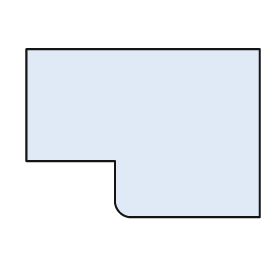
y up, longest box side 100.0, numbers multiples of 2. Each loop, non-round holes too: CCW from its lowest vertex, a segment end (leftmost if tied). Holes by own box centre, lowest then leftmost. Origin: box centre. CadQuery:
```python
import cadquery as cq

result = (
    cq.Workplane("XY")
    .moveTo(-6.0, -36.0)
    .lineTo(50.0, -36.0)
    .lineTo(50.0, 36.0)
    .lineTo(-50.0, 36.0)
    .lineTo(-50.0, -12.0)
    .lineTo(-12.0, -12.0)
    .lineTo(-12.0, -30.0)
    .threePointArc((-10.0, -34.0), (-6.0, -36.0))
    .close()
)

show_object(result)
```